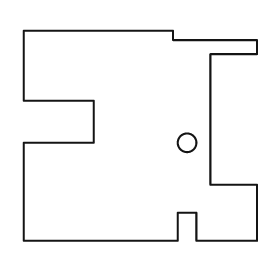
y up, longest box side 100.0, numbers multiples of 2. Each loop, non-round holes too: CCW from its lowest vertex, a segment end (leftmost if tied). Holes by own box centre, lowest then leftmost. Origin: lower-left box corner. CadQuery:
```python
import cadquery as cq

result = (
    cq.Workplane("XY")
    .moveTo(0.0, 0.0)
    .lineTo(66.0, 0.0)
    .lineTo(66.0, 12.0)
    .lineTo(74.0, 12.0)
    .lineTo(74.0, 0.0)
    .lineTo(100.0, 0.0)
    .lineTo(100.0, 24.0)
    .lineTo(80.0, 24.0)
    .lineTo(80.0, 80.0)
    .lineTo(100.0, 80.0)
    .lineTo(100.0, 86.0)
    .lineTo(64.0, 86.0)
    .lineTo(64.0, 90.0)
    .lineTo(0.0, 90.0)
    .lineTo(0.0, 60.0)
    .lineTo(30.0, 60.0)
    .lineTo(30.0, 42.0)
    .lineTo(0.0, 42.0)
    .close()
    .moveTo(70.0, 42.0)
    .circle(4.0)
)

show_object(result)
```